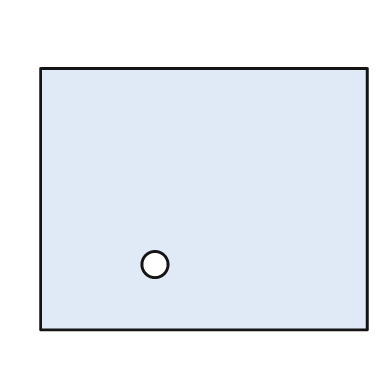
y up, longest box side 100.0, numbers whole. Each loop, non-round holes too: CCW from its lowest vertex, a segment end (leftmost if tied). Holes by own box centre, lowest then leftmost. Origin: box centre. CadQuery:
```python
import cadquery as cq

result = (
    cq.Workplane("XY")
    .moveTo(-50.0, -40.0)
    .lineTo(50.0, -40.0)
    .lineTo(50.0, 40.0)
    .lineTo(-50.0, 40.0)
    .close()
    .moveTo(-15.0, -20.0)
    .circle(4.0)
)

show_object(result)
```